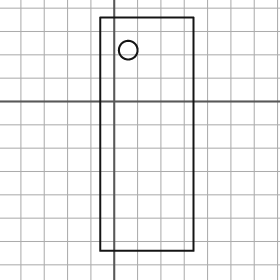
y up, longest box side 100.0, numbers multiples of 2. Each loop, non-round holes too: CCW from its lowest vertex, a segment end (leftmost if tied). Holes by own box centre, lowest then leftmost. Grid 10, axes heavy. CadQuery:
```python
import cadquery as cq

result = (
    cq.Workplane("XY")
    .moveTo(-6.0, -64.0)
    .lineTo(34.0, -64.0)
    .lineTo(34.0, 36.0)
    .lineTo(-6.0, 36.0)
    .close()
    .moveTo(6.0, 22.0)
    .circle(4.0)
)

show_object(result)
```